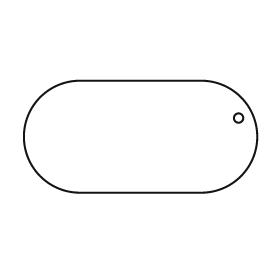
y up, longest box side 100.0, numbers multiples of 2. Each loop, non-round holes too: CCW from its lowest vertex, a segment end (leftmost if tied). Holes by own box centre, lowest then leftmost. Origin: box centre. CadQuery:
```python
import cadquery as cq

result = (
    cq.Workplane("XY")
    .moveTo(-26.0, -24.0)
    .lineTo(26.0, -24.0)
    .threePointArc((50.0, 0.0), (26.0, 24.0))
    .lineTo(-26.0, 24.0)
    .threePointArc((-50.0, 0.0), (-26.0, -24.0))
    .close()
    .moveTo(42.0, 8.0)
    .circle(2.0)
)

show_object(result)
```